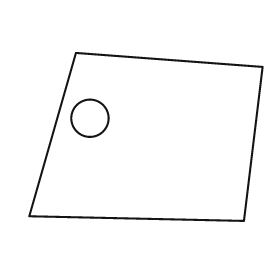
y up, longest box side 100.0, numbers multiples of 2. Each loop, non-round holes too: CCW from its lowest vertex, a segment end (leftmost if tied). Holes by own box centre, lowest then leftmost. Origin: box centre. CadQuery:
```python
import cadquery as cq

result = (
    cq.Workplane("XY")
    .moveTo(42.0, -36.0)
    .lineTo(50.0, 30.0)
    .lineTo(-30.0, 36.0)
    .lineTo(-50.0, -34.0)
    .close()
    .moveTo(-24.0, 8.0)
    .circle(8.0)
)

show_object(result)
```